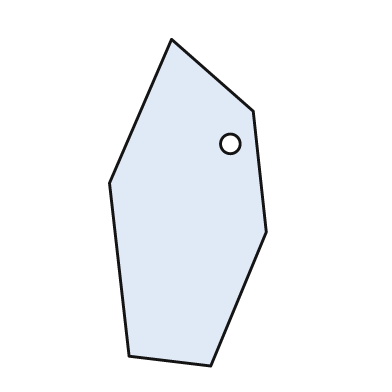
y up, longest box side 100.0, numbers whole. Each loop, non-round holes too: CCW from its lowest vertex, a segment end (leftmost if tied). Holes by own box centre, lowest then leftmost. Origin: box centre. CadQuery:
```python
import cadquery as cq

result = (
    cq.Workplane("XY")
    .moveTo(7.0, -50.0)
    .lineTo(24.0, -9.0)
    .lineTo(20.0, 28.0)
    .lineTo(-5.0, 50.0)
    .lineTo(-24.0, 6.0)
    .lineTo(-18.0, -47.0)
    .close()
    .moveTo(13.0, 18.0)
    .circle(3.0)
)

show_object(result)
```